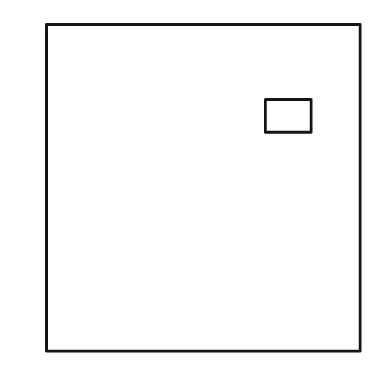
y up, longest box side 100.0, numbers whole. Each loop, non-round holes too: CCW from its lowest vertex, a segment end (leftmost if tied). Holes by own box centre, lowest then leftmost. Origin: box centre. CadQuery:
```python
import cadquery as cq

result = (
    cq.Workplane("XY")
    .moveTo(-48.0, -50.0)
    .lineTo(48.0, -50.0)
    .lineTo(48.0, 50.0)
    .lineTo(-48.0, 50.0)
    .close()
    .moveTo(19.0, 17.0)
    .lineTo(33.0, 17.0)
    .lineTo(33.0, 27.0)
    .lineTo(19.0, 27.0)
    .close()
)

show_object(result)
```